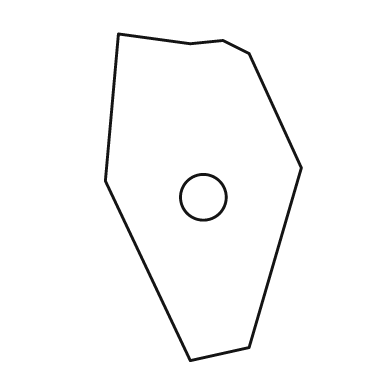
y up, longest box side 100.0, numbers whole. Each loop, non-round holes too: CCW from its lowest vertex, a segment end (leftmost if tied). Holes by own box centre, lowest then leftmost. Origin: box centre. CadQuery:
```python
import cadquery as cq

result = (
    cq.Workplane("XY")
    .moveTo(-4.0, -50.0)
    .lineTo(14.0, -46.0)
    .lineTo(30.0, 9.0)
    .lineTo(14.0, 44.0)
    .lineTo(6.0, 48.0)
    .lineTo(-4.0, 47.0)
    .lineTo(-26.0, 50.0)
    .lineTo(-30.0, 5.0)
    .close()
    .moveTo(0.0, 0.0)
    .circle(7.0)
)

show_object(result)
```